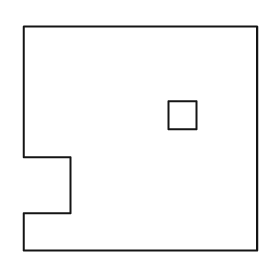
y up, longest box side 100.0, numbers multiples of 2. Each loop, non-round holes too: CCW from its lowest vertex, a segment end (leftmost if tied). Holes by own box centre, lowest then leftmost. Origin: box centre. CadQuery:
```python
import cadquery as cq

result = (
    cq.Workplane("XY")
    .moveTo(-50.0, -48.0)
    .lineTo(50.0, -48.0)
    .lineTo(50.0, 48.0)
    .lineTo(-50.0, 48.0)
    .lineTo(-50.0, -8.0)
    .lineTo(-30.0, -8.0)
    .lineTo(-30.0, -32.0)
    .lineTo(-50.0, -32.0)
    .close()
    .moveTo(12.0, 4.0)
    .lineTo(24.0, 4.0)
    .lineTo(24.0, 16.0)
    .lineTo(12.0, 16.0)
    .close()
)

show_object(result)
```